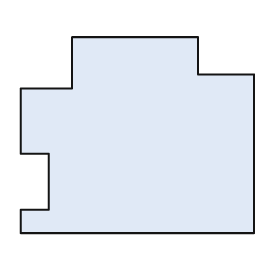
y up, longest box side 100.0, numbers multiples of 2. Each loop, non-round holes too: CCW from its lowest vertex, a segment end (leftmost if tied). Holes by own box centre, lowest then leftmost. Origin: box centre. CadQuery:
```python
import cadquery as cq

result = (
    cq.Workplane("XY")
    .moveTo(-50.0, -42.0)
    .lineTo(50.0, -42.0)
    .lineTo(50.0, 26.0)
    .lineTo(26.0, 26.0)
    .lineTo(26.0, 42.0)
    .lineTo(-28.0, 42.0)
    .lineTo(-28.0, 20.0)
    .lineTo(-50.0, 20.0)
    .lineTo(-50.0, -8.0)
    .lineTo(-38.0, -8.0)
    .lineTo(-38.0, -32.0)
    .lineTo(-50.0, -32.0)
    .close()
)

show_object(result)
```